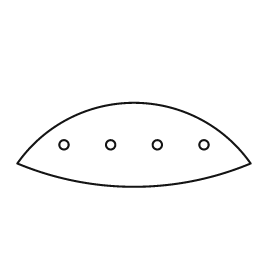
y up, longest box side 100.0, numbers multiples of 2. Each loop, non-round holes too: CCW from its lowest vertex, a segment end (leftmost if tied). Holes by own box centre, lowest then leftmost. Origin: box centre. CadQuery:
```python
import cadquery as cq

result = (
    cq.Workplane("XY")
    .moveTo(-50.0, -8.0)
    .threePointArc((0.0, -18.0), (50.0, -8.0))
    .threePointArc((0.0, 18.0), (-50.0, -8.0))
    .close()
    .moveTo(-30.0, 0.0)
    .circle(2.0)
    .moveTo(-10.0, 0.0)
    .circle(2.0)
    .moveTo(10.0, 0.0)
    .circle(2.0)
    .moveTo(30.0, 0.0)
    .circle(2.0)
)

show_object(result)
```